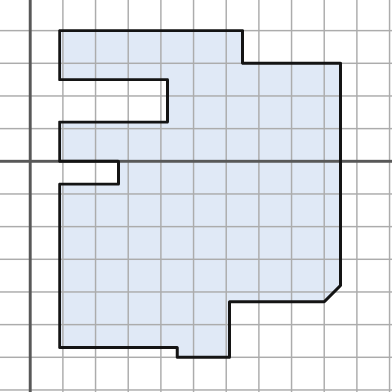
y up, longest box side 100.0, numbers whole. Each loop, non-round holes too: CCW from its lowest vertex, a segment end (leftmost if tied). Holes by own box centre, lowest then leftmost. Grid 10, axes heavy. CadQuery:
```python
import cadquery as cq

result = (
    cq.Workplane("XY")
    .moveTo(45.0, -60.0)
    .lineTo(61.0, -60.0)
    .lineTo(61.0, -43.0)
    .lineTo(90.0, -43.0)
    .lineTo(95.0, -38.0)
    .lineTo(95.0, 30.0)
    .lineTo(65.0, 30.0)
    .lineTo(65.0, 40.0)
    .lineTo(9.0, 40.0)
    .lineTo(9.0, 25.0)
    .lineTo(42.0, 25.0)
    .lineTo(42.0, 12.0)
    .lineTo(9.0, 12.0)
    .lineTo(9.0, 0.0)
    .lineTo(27.0, 0.0)
    .lineTo(27.0, -7.0)
    .lineTo(9.0, -7.0)
    .lineTo(9.0, -57.0)
    .lineTo(45.0, -57.0)
    .close()
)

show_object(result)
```